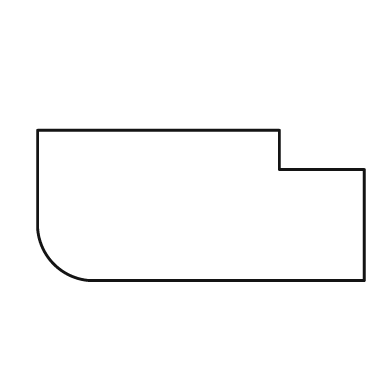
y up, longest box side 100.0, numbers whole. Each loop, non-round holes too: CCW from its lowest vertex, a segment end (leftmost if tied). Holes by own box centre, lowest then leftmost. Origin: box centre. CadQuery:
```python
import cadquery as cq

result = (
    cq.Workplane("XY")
    .moveTo(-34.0, -23.0)
    .lineTo(50.0, -23.0)
    .lineTo(50.0, 11.0)
    .lineTo(24.0, 11.0)
    .lineTo(24.0, 23.0)
    .lineTo(-50.0, 23.0)
    .lineTo(-50.0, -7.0)
    .threePointArc((-45.0, -18.0), (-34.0, -23.0))
    .close()
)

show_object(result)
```